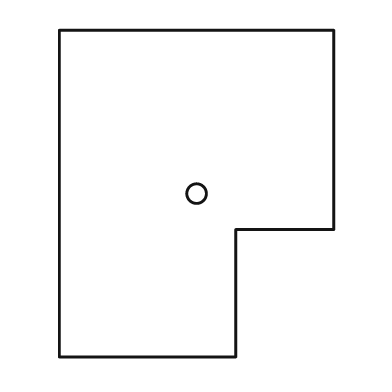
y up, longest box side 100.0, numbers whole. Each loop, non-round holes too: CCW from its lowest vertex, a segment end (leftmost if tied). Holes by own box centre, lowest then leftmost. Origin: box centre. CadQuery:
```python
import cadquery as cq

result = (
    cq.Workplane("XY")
    .moveTo(-42.0, -50.0)
    .lineTo(12.0, -50.0)
    .lineTo(12.0, -11.0)
    .lineTo(42.0, -11.0)
    .lineTo(42.0, 50.0)
    .lineTo(-42.0, 50.0)
    .close()
    .moveTo(0.0, 0.0)
    .circle(3.0)
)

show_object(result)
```